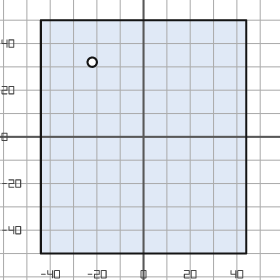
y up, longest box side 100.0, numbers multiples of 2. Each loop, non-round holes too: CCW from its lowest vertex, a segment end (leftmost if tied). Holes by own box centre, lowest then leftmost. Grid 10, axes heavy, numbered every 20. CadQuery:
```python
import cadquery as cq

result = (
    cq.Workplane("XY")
    .moveTo(-44.0, -50.0)
    .lineTo(44.0, -50.0)
    .lineTo(44.0, 50.0)
    .lineTo(-44.0, 50.0)
    .close()
    .moveTo(-22.0, 32.0)
    .circle(2.0)
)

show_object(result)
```